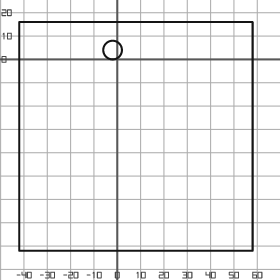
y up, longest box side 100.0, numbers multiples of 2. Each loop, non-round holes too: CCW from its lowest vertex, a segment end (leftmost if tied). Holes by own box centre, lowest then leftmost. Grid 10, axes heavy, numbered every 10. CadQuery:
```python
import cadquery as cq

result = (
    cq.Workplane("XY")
    .moveTo(-42.0, -82.0)
    .lineTo(58.0, -82.0)
    .lineTo(58.0, 16.0)
    .lineTo(-42.0, 16.0)
    .close()
    .moveTo(-2.0, 4.0)
    .circle(4.0)
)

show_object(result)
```